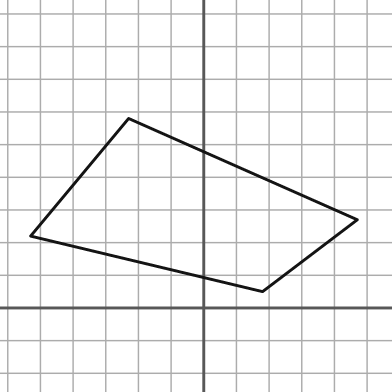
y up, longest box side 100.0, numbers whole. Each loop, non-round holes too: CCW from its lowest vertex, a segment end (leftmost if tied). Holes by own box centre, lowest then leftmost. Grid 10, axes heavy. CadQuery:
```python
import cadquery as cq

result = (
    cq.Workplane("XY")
    .moveTo(18.0, 5.0)
    .lineTo(47.0, 27.0)
    .lineTo(-23.0, 58.0)
    .lineTo(-53.0, 22.0)
    .close()
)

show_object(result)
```